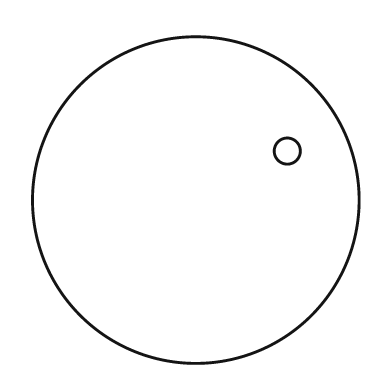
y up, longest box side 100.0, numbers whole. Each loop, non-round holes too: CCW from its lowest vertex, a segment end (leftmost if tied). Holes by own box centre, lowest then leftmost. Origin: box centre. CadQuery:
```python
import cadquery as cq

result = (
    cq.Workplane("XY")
    .moveTo(0.0, 0.0)
    .circle(50.0)
    .moveTo(28.0, 15.0)
    .circle(4.0)
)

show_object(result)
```